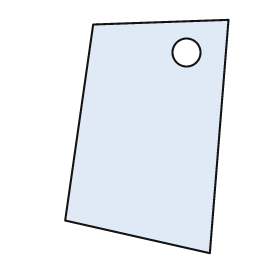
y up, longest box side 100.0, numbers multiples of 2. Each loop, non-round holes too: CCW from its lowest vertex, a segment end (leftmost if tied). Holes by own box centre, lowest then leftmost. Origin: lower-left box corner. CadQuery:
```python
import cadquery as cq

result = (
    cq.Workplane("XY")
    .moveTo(62.0, 0.0)
    .lineTo(70.0, 100.0)
    .lineTo(12.0, 98.0)
    .lineTo(0.0, 14.0)
    .close()
    .moveTo(52.0, 86.0)
    .circle(6.0)
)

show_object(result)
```